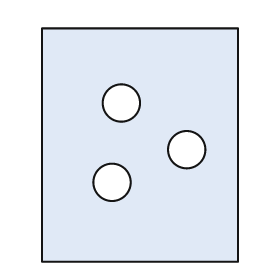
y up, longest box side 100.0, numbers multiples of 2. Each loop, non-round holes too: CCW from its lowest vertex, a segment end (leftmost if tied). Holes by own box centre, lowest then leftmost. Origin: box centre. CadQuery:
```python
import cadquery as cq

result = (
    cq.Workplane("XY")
    .moveTo(-42.0, -50.0)
    .lineTo(42.0, -50.0)
    .lineTo(42.0, 50.0)
    .lineTo(-42.0, 50.0)
    .close()
    .moveTo(-12.0, -16.0)
    .circle(8.0)
    .moveTo(20.0, -2.0)
    .circle(8.0)
    .moveTo(-8.0, 18.0)
    .circle(8.0)
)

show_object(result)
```